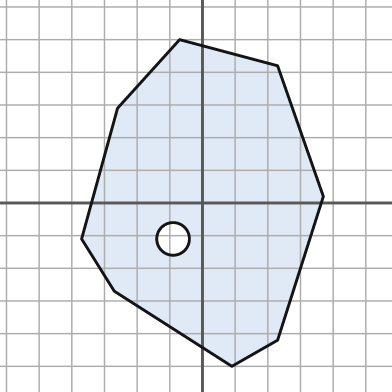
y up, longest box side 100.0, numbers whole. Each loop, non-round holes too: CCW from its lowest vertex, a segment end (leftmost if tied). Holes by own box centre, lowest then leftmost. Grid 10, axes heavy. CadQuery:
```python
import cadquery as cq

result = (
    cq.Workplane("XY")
    .moveTo(9.0, -50.0)
    .lineTo(23.0, -42.0)
    .lineTo(37.0, 2.0)
    .lineTo(23.0, 42.0)
    .lineTo(-7.0, 50.0)
    .lineTo(-26.0, 29.0)
    .lineTo(-37.0, -11.0)
    .lineTo(-27.0, -27.0)
    .close()
    .moveTo(-9.0, -11.0)
    .circle(5.0)
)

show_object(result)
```